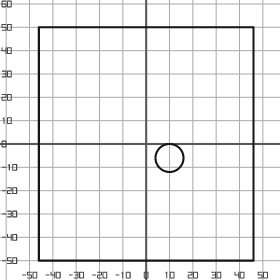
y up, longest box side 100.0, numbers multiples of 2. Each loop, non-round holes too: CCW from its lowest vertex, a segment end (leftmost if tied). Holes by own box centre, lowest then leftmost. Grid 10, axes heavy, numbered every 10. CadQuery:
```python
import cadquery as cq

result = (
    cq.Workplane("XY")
    .moveTo(-46.0, -50.0)
    .lineTo(46.0, -50.0)
    .lineTo(46.0, 50.0)
    .lineTo(-46.0, 50.0)
    .close()
    .moveTo(10.0, -6.0)
    .circle(6.0)
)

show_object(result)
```